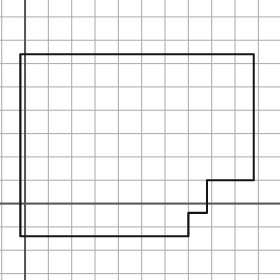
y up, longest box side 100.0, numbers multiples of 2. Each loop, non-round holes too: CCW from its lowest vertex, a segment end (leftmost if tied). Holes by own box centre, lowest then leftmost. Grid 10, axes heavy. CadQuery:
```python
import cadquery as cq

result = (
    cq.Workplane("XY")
    .moveTo(-2.0, -14.0)
    .lineTo(70.0, -14.0)
    .lineTo(70.0, -4.0)
    .lineTo(78.0, -4.0)
    .lineTo(78.0, 10.0)
    .lineTo(98.0, 10.0)
    .lineTo(98.0, 64.0)
    .lineTo(-2.0, 64.0)
    .close()
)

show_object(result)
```